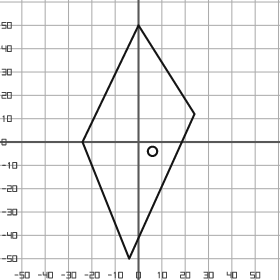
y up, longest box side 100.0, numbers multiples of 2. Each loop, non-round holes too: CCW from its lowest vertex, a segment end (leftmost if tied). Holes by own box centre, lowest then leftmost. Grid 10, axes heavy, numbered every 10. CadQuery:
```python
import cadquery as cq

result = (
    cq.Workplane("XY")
    .moveTo(-4.0, -50.0)
    .lineTo(24.0, 12.0)
    .lineTo(0.0, 50.0)
    .lineTo(-24.0, 0.0)
    .close()
    .moveTo(6.0, -4.0)
    .circle(2.0)
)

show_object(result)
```